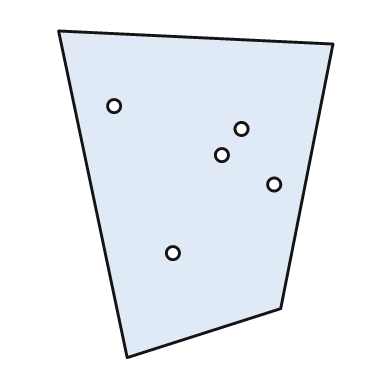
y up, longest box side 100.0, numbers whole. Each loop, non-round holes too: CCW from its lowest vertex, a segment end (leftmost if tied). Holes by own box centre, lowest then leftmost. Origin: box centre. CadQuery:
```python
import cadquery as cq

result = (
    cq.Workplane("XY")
    .moveTo(-21.0, -50.0)
    .lineTo(26.0, -35.0)
    .lineTo(42.0, 46.0)
    .lineTo(-42.0, 50.0)
    .close()
    .moveTo(-7.0, -18.0)
    .circle(2.0)
    .moveTo(24.0, 3.0)
    .circle(2.0)
    .moveTo(8.0, 12.0)
    .circle(2.0)
    .moveTo(14.0, 20.0)
    .circle(2.0)
    .moveTo(-25.0, 27.0)
    .circle(2.0)
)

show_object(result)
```